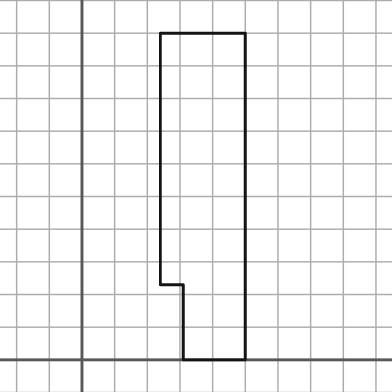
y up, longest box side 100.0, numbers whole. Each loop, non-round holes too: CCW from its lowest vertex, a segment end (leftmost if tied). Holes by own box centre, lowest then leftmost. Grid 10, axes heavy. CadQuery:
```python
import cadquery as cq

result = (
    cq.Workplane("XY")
    .moveTo(31.0, 0.0)
    .lineTo(50.0, 0.0)
    .lineTo(50.0, 100.0)
    .lineTo(24.0, 100.0)
    .lineTo(24.0, 23.0)
    .lineTo(31.0, 23.0)
    .close()
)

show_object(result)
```